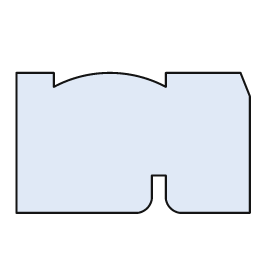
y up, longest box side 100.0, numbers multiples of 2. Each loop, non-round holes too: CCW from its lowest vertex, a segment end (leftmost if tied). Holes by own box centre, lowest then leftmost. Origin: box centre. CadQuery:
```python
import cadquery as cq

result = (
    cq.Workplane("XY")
    .moveTo(-50.0, -30.0)
    .lineTo(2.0, -30.0)
    .threePointArc((6.0, -28.0), (8.0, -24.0))
    .lineTo(8.0, -14.0)
    .lineTo(14.0, -14.0)
    .lineTo(14.0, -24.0)
    .threePointArc((16.0, -28.0), (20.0, -30.0))
    .lineTo(50.0, -30.0)
    .lineTo(50.0, 20.0)
    .lineTo(46.0, 30.0)
    .lineTo(14.0, 30.0)
    .lineTo(14.0, 24.0)
    .threePointArc((-10.0, 30.0), (-34.0, 24.0))
    .lineTo(-34.0, 30.0)
    .lineTo(-50.0, 30.0)
    .close()
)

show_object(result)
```